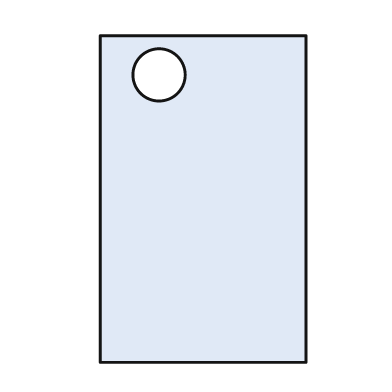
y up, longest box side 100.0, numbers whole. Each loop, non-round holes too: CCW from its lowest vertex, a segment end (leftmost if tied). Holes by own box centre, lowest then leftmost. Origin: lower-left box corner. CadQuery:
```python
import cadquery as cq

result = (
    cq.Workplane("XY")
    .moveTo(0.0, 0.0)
    .lineTo(63.0, 0.0)
    .lineTo(63.0, 100.0)
    .lineTo(0.0, 100.0)
    .close()
    .moveTo(18.0, 88.0)
    .circle(8.0)
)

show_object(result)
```